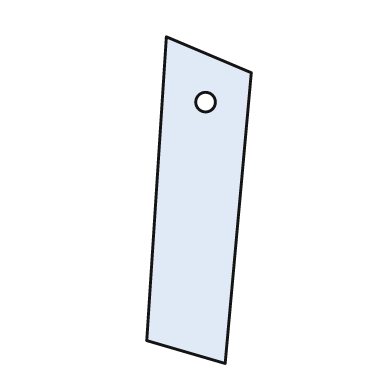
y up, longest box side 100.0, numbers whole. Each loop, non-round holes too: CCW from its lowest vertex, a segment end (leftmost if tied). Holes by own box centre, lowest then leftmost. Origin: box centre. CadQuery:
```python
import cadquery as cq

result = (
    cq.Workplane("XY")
    .moveTo(8.0, -50.0)
    .lineTo(16.0, 39.0)
    .lineTo(-10.0, 50.0)
    .lineTo(-16.0, -43.0)
    .close()
    .moveTo(2.0, 30.0)
    .circle(3.0)
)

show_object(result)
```